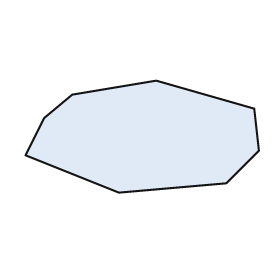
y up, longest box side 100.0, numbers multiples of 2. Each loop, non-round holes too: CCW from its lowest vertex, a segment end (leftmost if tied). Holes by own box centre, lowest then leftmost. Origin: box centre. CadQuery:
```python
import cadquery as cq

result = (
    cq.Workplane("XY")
    .moveTo(-10.0, -24.0)
    .lineTo(36.0, -20.0)
    .lineTo(50.0, -6.0)
    .lineTo(48.0, 12.0)
    .lineTo(6.0, 24.0)
    .lineTo(-30.0, 18.0)
    .lineTo(-42.0, 8.0)
    .lineTo(-50.0, -8.0)
    .close()
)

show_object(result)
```